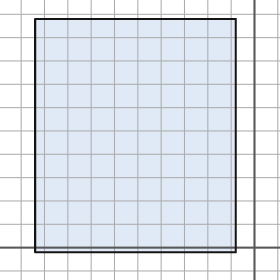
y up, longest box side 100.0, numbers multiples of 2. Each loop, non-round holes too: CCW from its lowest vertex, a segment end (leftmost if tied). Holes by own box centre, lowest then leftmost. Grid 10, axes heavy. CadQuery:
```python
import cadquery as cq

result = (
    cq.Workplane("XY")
    .moveTo(-94.0, -2.0)
    .lineTo(-8.0, -2.0)
    .lineTo(-8.0, 98.0)
    .lineTo(-94.0, 98.0)
    .close()
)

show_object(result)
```